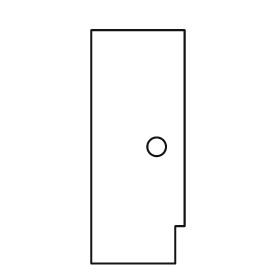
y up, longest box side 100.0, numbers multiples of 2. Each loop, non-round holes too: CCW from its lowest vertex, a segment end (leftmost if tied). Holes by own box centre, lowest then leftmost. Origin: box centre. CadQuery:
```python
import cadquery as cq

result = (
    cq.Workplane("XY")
    .moveTo(-20.0, -50.0)
    .lineTo(16.0, -50.0)
    .lineTo(16.0, -34.0)
    .lineTo(20.0, -34.0)
    .lineTo(20.0, 50.0)
    .lineTo(-20.0, 50.0)
    .close()
    .moveTo(8.0, 0.0)
    .circle(4.0)
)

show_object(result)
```